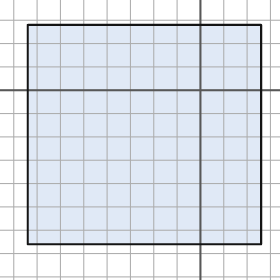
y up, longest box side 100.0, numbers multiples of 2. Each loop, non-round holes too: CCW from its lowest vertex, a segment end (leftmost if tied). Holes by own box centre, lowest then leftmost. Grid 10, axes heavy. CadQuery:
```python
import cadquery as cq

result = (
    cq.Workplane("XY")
    .moveTo(-74.0, -66.0)
    .lineTo(26.0, -66.0)
    .lineTo(26.0, 28.0)
    .lineTo(-74.0, 28.0)
    .close()
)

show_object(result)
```